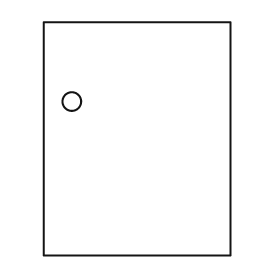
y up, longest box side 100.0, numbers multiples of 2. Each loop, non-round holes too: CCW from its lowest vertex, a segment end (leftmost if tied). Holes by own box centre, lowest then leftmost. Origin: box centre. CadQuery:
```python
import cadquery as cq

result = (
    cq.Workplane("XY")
    .moveTo(-40.0, -50.0)
    .lineTo(40.0, -50.0)
    .lineTo(40.0, 50.0)
    .lineTo(-40.0, 50.0)
    .close()
    .moveTo(-28.0, 16.0)
    .circle(4.0)
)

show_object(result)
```